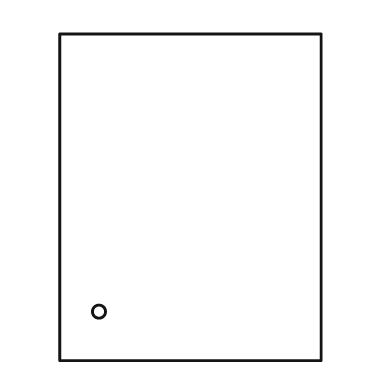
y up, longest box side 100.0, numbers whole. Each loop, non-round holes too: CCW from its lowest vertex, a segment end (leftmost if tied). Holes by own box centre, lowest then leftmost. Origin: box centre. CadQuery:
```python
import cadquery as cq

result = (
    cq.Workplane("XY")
    .moveTo(-40.0, -50.0)
    .lineTo(40.0, -50.0)
    .lineTo(40.0, 50.0)
    .lineTo(-40.0, 50.0)
    .close()
    .moveTo(-28.0, -35.0)
    .circle(2.0)
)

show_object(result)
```